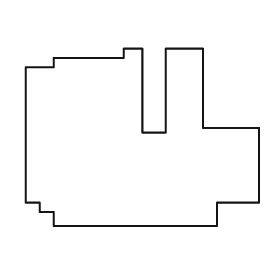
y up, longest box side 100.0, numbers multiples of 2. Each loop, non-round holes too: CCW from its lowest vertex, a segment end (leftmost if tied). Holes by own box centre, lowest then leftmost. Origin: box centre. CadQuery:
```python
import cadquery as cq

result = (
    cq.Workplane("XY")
    .moveTo(-38.0, -38.0)
    .lineTo(32.0, -38.0)
    .lineTo(32.0, -28.0)
    .lineTo(50.0, -28.0)
    .lineTo(50.0, 4.0)
    .lineTo(26.0, 4.0)
    .lineTo(26.0, 38.0)
    .lineTo(10.0, 38.0)
    .lineTo(10.0, 2.0)
    .lineTo(0.0, 2.0)
    .lineTo(0.0, 38.0)
    .lineTo(-8.0, 38.0)
    .lineTo(-8.0, 34.0)
    .lineTo(-38.0, 34.0)
    .lineTo(-38.0, 30.0)
    .lineTo(-50.0, 30.0)
    .lineTo(-50.0, -28.0)
    .lineTo(-44.0, -28.0)
    .lineTo(-44.0, -32.0)
    .lineTo(-38.0, -32.0)
    .close()
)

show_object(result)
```